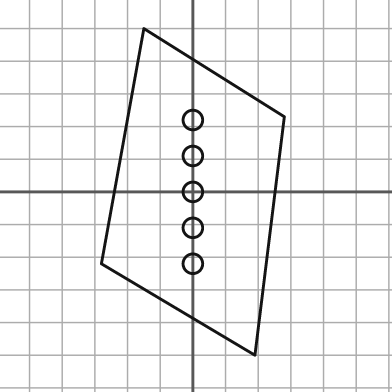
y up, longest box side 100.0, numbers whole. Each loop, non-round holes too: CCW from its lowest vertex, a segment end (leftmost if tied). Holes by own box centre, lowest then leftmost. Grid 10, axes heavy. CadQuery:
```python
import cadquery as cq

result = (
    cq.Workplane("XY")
    .moveTo(19.0, -50.0)
    .lineTo(28.0, 23.0)
    .lineTo(-15.0, 50.0)
    .lineTo(-28.0, -22.0)
    .close()
    .moveTo(0.0, -22.0)
    .circle(3.0)
    .moveTo(0.0, -11.0)
    .circle(3.0)
    .moveTo(0.0, 0.0)
    .circle(3.0)
    .moveTo(0.0, 11.0)
    .circle(3.0)
    .moveTo(0.0, 22.0)
    .circle(3.0)
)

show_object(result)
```